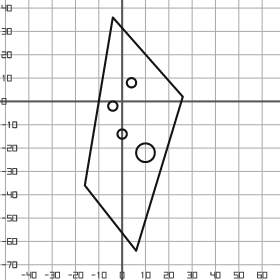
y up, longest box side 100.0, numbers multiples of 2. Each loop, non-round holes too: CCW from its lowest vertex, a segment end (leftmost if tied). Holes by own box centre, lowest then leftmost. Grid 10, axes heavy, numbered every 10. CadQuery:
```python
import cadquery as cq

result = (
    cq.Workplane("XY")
    .moveTo(6.0, -64.0)
    .lineTo(26.0, 2.0)
    .lineTo(-4.0, 36.0)
    .lineTo(-16.0, -36.0)
    .close()
    .moveTo(10.0, -22.0)
    .circle(4.0)
    .moveTo(0.0, -14.0)
    .circle(2.0)
    .moveTo(-4.0, -2.0)
    .circle(2.0)
    .moveTo(4.0, 8.0)
    .circle(2.0)
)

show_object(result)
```